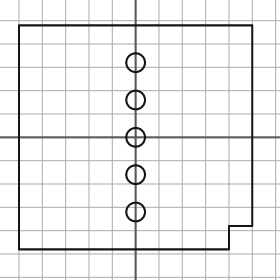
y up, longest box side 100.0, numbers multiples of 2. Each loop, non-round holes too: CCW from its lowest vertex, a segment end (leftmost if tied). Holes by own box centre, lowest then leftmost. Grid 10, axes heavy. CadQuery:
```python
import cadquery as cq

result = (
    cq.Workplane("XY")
    .moveTo(-50.0, -48.0)
    .lineTo(40.0, -48.0)
    .lineTo(40.0, -38.0)
    .lineTo(50.0, -38.0)
    .lineTo(50.0, 48.0)
    .lineTo(-50.0, 48.0)
    .close()
    .moveTo(0.0, -32.0)
    .circle(4.0)
    .moveTo(0.0, -16.0)
    .circle(4.0)
    .moveTo(0.0, 0.0)
    .circle(4.0)
    .moveTo(0.0, 16.0)
    .circle(4.0)
    .moveTo(0.0, 32.0)
    .circle(4.0)
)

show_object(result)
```